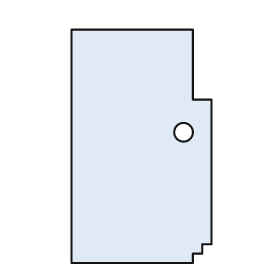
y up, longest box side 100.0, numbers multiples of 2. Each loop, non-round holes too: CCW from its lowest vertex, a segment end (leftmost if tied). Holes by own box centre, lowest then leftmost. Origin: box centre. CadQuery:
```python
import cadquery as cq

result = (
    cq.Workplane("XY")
    .moveTo(-30.0, -50.0)
    .lineTo(22.0, -50.0)
    .lineTo(22.0, -46.0)
    .lineTo(26.0, -46.0)
    .lineTo(26.0, -42.0)
    .lineTo(30.0, -42.0)
    .lineTo(30.0, 20.0)
    .lineTo(22.0, 20.0)
    .lineTo(22.0, 50.0)
    .lineTo(-30.0, 50.0)
    .close()
    .moveTo(18.0, 6.0)
    .circle(4.0)
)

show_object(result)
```